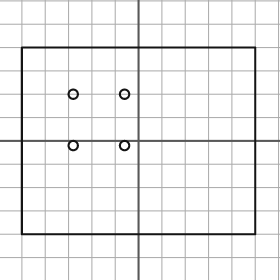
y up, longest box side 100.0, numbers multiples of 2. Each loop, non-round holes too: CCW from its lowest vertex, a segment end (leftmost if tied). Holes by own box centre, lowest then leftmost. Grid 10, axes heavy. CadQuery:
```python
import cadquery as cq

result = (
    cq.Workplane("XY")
    .moveTo(-50.0, -40.0)
    .lineTo(50.0, -40.0)
    .lineTo(50.0, 40.0)
    .lineTo(-50.0, 40.0)
    .close()
    .moveTo(-28.0, -2.0)
    .circle(2.0)
    .moveTo(-6.0, -2.0)
    .circle(2.0)
    .moveTo(-28.0, 20.0)
    .circle(2.0)
    .moveTo(-6.0, 20.0)
    .circle(2.0)
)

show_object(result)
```